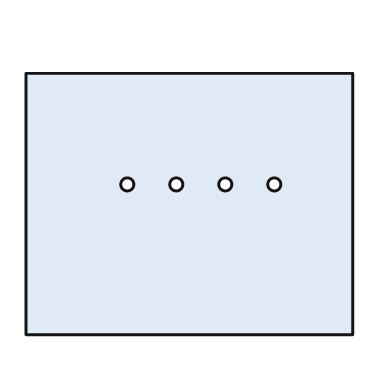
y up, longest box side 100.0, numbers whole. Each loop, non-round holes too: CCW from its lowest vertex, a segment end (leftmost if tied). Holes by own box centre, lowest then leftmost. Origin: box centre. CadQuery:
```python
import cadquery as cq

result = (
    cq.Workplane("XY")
    .moveTo(-50.0, -40.0)
    .lineTo(50.0, -40.0)
    .lineTo(50.0, 40.0)
    .lineTo(-50.0, 40.0)
    .close()
    .moveTo(-19.0, 6.0)
    .circle(2.0)
    .moveTo(-4.0, 6.0)
    .circle(2.0)
    .moveTo(11.0, 6.0)
    .circle(2.0)
    .moveTo(26.0, 6.0)
    .circle(2.0)
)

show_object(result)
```